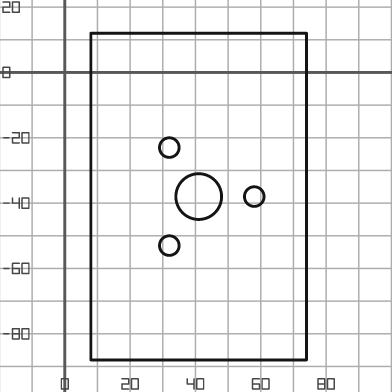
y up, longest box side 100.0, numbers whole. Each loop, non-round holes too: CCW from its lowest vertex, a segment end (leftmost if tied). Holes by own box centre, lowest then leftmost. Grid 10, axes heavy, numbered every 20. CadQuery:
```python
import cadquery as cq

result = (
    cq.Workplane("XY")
    .moveTo(8.0, -88.0)
    .lineTo(74.0, -88.0)
    .lineTo(74.0, 12.0)
    .lineTo(8.0, 12.0)
    .close()
    .moveTo(32.0, -53.0)
    .circle(3.0)
    .moveTo(41.0, -38.0)
    .circle(7.0)
    .moveTo(58.0, -38.0)
    .circle(3.0)
    .moveTo(32.0, -23.0)
    .circle(3.0)
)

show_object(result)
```